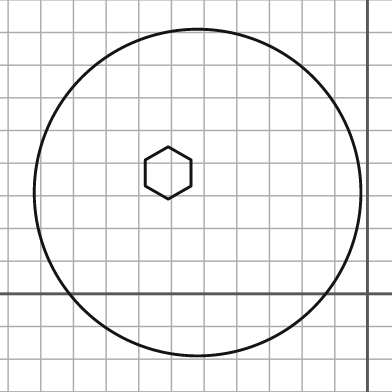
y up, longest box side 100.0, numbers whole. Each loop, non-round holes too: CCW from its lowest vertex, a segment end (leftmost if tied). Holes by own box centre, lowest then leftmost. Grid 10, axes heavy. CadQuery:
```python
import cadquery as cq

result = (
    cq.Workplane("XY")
    .moveTo(-52.0, 31.0)
    .circle(50.0)
    .moveTo(-61.0, 29.0)
    .lineTo(-54.0, 33.0)
    .lineTo(-54.0, 41.0)
    .lineTo(-61.0, 45.0)
    .lineTo(-68.0, 41.0)
    .lineTo(-68.0, 33.0)
    .close()
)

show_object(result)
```